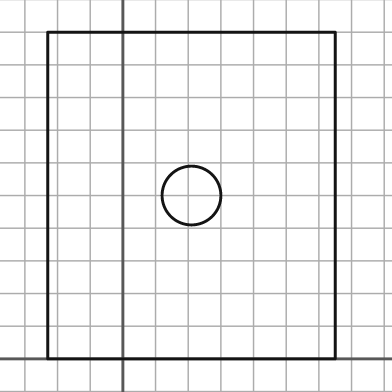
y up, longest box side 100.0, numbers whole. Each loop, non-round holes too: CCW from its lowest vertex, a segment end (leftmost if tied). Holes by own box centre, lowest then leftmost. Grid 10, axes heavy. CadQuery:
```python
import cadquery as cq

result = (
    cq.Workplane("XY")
    .moveTo(-23.0, 0.0)
    .lineTo(65.0, 0.0)
    .lineTo(65.0, 100.0)
    .lineTo(-23.0, 100.0)
    .close()
    .moveTo(21.0, 50.0)
    .circle(9.0)
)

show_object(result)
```